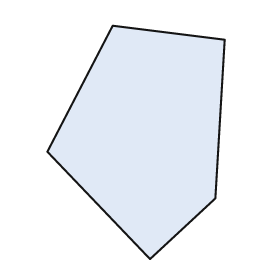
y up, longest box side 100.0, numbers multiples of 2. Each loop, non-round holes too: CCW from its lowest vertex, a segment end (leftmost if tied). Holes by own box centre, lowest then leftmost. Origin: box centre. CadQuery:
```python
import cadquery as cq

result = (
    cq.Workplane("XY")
    .moveTo(6.0, -50.0)
    .lineTo(34.0, -24.0)
    .lineTo(38.0, 44.0)
    .lineTo(-10.0, 50.0)
    .lineTo(-38.0, -4.0)
    .close()
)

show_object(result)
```